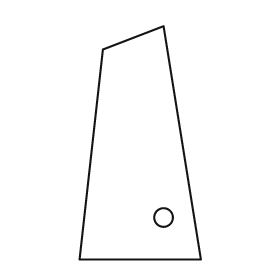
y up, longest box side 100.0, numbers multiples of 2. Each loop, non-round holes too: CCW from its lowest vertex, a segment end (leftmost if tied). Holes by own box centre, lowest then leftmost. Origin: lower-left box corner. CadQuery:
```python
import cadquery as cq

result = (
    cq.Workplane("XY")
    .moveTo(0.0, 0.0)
    .lineTo(52.0, 0.0)
    .lineTo(36.0, 100.0)
    .lineTo(10.0, 90.0)
    .close()
    .moveTo(36.0, 18.0)
    .circle(4.0)
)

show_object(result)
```